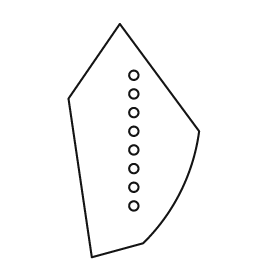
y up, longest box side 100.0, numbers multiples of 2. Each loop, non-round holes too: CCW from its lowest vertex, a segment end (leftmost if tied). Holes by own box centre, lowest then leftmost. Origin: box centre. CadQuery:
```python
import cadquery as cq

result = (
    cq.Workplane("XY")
    .moveTo(-18.0, -50.0)
    .lineTo(4.0, -44.0)
    .threePointArc((20.0, -22.0), (28.0, 4.0))
    .lineTo(-6.0, 50.0)
    .lineTo(-28.0, 18.0)
    .close()
    .moveTo(0.0, -28.0)
    .circle(2.0)
    .moveTo(0.0, -20.0)
    .circle(2.0)
    .moveTo(0.0, -12.0)
    .circle(2.0)
    .moveTo(0.0, -4.0)
    .circle(2.0)
    .moveTo(0.0, 4.0)
    .circle(2.0)
    .moveTo(0.0, 12.0)
    .circle(2.0)
    .moveTo(0.0, 20.0)
    .circle(2.0)
    .moveTo(0.0, 28.0)
    .circle(2.0)
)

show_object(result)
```